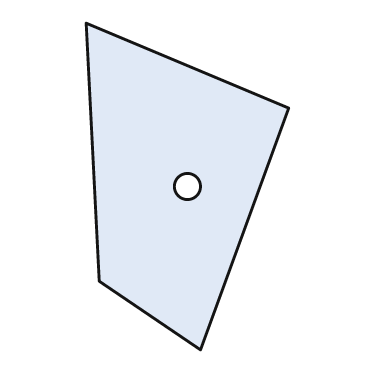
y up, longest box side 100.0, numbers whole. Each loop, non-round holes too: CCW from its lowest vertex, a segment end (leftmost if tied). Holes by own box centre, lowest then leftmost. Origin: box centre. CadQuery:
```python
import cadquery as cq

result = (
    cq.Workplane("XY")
    .moveTo(4.0, -50.0)
    .lineTo(31.0, 24.0)
    .lineTo(-31.0, 50.0)
    .lineTo(-27.0, -29.0)
    .close()
    .moveTo(0.0, 0.0)
    .circle(4.0)
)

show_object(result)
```